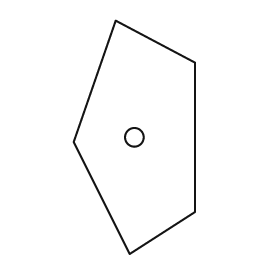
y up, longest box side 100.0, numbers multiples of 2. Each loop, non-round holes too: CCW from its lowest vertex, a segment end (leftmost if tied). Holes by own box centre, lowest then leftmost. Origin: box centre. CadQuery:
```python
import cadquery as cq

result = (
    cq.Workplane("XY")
    .moveTo(-2.0, -50.0)
    .lineTo(26.0, -32.0)
    .lineTo(26.0, 32.0)
    .lineTo(-8.0, 50.0)
    .lineTo(-26.0, -2.0)
    .close()
    .moveTo(0.0, 0.0)
    .circle(4.0)
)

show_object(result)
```